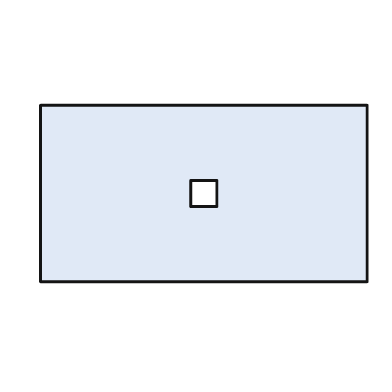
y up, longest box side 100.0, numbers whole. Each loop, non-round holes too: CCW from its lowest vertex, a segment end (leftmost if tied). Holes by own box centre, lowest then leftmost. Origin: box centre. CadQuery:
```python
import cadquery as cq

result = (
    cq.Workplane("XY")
    .moveTo(-50.0, -27.0)
    .lineTo(50.0, -27.0)
    .lineTo(50.0, 27.0)
    .lineTo(-50.0, 27.0)
    .close()
    .moveTo(-4.0, -4.0)
    .lineTo(4.0, -4.0)
    .lineTo(4.0, 4.0)
    .lineTo(-4.0, 4.0)
    .close()
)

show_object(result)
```